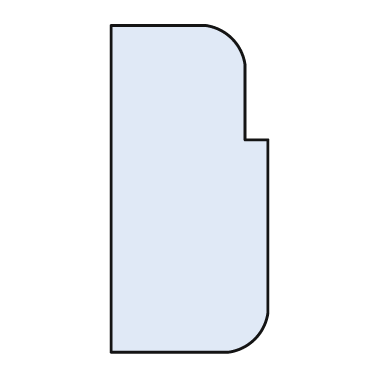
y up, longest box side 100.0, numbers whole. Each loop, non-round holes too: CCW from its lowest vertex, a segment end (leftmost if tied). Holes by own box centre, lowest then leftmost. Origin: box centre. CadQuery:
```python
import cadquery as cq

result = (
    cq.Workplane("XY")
    .moveTo(-24.0, -50.0)
    .lineTo(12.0, -50.0)
    .threePointArc((20.0, -46.0), (24.0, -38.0))
    .lineTo(24.0, 15.0)
    .lineTo(17.0, 15.0)
    .lineTo(17.0, 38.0)
    .threePointArc((13.0, 46.0), (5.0, 50.0))
    .lineTo(-24.0, 50.0)
    .close()
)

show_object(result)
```